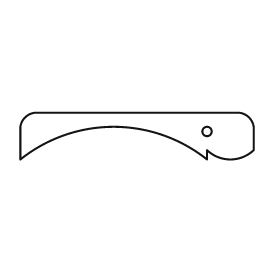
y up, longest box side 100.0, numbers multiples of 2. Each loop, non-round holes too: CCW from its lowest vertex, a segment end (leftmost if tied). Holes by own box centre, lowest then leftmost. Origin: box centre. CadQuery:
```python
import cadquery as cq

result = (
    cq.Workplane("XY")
    .moveTo(-50.0, -10.0)
    .threePointArc((-10.0, 4.0), (30.0, -10.0))
    .lineTo(30.0, -6.0)
    .threePointArc((40.0, -10.0), (50.0, -6.0))
    .lineTo(50.0, 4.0)
    .threePointArc((48.0, 8.0), (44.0, 10.0))
    .lineTo(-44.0, 10.0)
    .threePointArc((-48.0, 8.0), (-50.0, 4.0))
    .close()
    .moveTo(30.0, 2.0)
    .circle(2.0)
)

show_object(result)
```